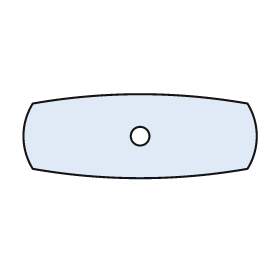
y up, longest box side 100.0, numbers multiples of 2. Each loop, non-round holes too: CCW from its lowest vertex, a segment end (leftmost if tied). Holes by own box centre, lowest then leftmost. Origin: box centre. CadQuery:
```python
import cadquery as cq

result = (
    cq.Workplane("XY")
    .moveTo(-46.0, -14.0)
    .threePointArc((0.0, -18.0), (46.0, -14.0))
    .threePointArc((50.0, 0.0), (46.0, 14.0))
    .threePointArc((0.0, 18.0), (-46.0, 14.0))
    .threePointArc((-50.0, 0.0), (-46.0, -14.0))
    .close()
    .moveTo(0.0, 0.0)
    .circle(4.0)
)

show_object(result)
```